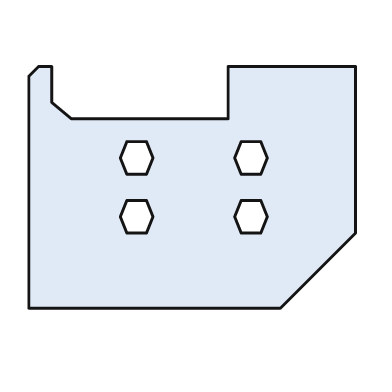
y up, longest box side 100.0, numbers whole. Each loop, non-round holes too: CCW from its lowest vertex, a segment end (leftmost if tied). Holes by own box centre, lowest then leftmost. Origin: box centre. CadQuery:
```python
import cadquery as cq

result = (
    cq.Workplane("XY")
    .moveTo(-50.0, -37.0)
    .lineTo(27.0, -37.0)
    .lineTo(50.0, -14.0)
    .lineTo(50.0, 37.0)
    .lineTo(11.0, 37.0)
    .lineTo(11.0, 21.0)
    .lineTo(-37.0, 21.0)
    .lineTo(-43.0, 26.0)
    .lineTo(-43.0, 37.0)
    .lineTo(-47.0, 37.0)
    .lineTo(-50.0, 34.0)
    .close()
    .moveTo(-20.0, -14.0)
    .lineTo(-14.0, -14.0)
    .lineTo(-12.0, -9.0)
    .lineTo(-14.0, -4.0)
    .lineTo(-20.0, -4.0)
    .lineTo(-22.0, -9.0)
    .close()
    .moveTo(15.0, -14.0)
    .lineTo(21.0, -14.0)
    .lineTo(23.0, -9.0)
    .lineTo(21.0, -4.0)
    .lineTo(15.0, -4.0)
    .lineTo(13.0, -9.0)
    .close()
    .moveTo(-20.0, 4.0)
    .lineTo(-14.0, 4.0)
    .lineTo(-12.0, 9.0)
    .lineTo(-14.0, 14.0)
    .lineTo(-20.0, 14.0)
    .lineTo(-22.0, 9.0)
    .close()
    .moveTo(15.0, 4.0)
    .lineTo(21.0, 4.0)
    .lineTo(23.0, 9.0)
    .lineTo(21.0, 14.0)
    .lineTo(15.0, 14.0)
    .lineTo(13.0, 9.0)
    .close()
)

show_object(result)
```